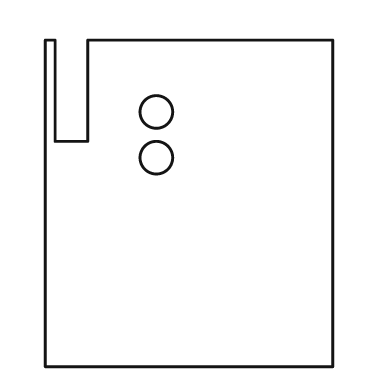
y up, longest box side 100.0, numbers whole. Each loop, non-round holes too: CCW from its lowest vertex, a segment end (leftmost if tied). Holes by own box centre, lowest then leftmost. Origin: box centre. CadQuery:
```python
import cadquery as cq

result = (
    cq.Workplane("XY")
    .moveTo(-44.0, -50.0)
    .lineTo(44.0, -50.0)
    .lineTo(44.0, 50.0)
    .lineTo(-31.0, 50.0)
    .lineTo(-31.0, 19.0)
    .lineTo(-41.0, 19.0)
    .lineTo(-41.0, 50.0)
    .lineTo(-44.0, 50.0)
    .close()
    .moveTo(-10.0, 14.0)
    .circle(5.0)
    .moveTo(-10.0, 28.0)
    .circle(5.0)
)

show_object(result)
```